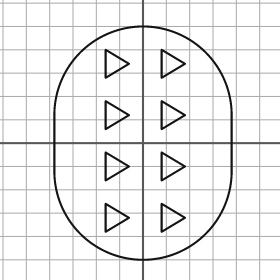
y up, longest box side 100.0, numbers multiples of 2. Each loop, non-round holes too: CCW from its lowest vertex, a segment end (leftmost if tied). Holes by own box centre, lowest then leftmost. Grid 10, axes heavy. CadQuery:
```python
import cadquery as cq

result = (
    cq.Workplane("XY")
    .moveTo(-38.0, -12.0)
    .threePointArc((0.0, -50.0), (38.0, -12.0))
    .lineTo(38.0, 12.0)
    .threePointArc((0.0, 50.0), (-38.0, 12.0))
    .close()
    .moveTo(-16.0, -38.0)
    .lineTo(-6.0, -32.0)
    .lineTo(-16.0, -26.0)
    .close()
    .moveTo(8.0, -38.0)
    .lineTo(18.0, -32.0)
    .lineTo(8.0, -26.0)
    .close()
    .moveTo(-16.0, -16.0)
    .lineTo(-6.0, -10.0)
    .lineTo(-16.0, -4.0)
    .close()
    .moveTo(8.0, -16.0)
    .lineTo(18.0, -10.0)
    .lineTo(8.0, -4.0)
    .close()
    .moveTo(-16.0, 6.0)
    .lineTo(-6.0, 12.0)
    .lineTo(-16.0, 18.0)
    .close()
    .moveTo(8.0, 6.0)
    .lineTo(18.0, 12.0)
    .lineTo(8.0, 18.0)
    .close()
    .moveTo(-16.0, 28.0)
    .lineTo(-6.0, 34.0)
    .lineTo(-16.0, 40.0)
    .close()
    .moveTo(8.0, 28.0)
    .lineTo(18.0, 34.0)
    .lineTo(8.0, 40.0)
    .close()
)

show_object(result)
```